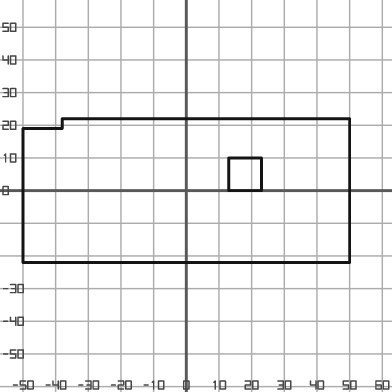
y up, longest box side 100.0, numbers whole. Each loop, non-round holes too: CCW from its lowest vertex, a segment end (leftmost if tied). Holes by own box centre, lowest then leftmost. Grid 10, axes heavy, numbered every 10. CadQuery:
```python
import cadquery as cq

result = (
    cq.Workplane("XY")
    .moveTo(-50.0, -22.0)
    .lineTo(50.0, -22.0)
    .lineTo(50.0, 22.0)
    .lineTo(-38.0, 22.0)
    .lineTo(-38.0, 19.0)
    .lineTo(-50.0, 19.0)
    .close()
    .moveTo(13.0, 0.0)
    .lineTo(23.0, 0.0)
    .lineTo(23.0, 10.0)
    .lineTo(13.0, 10.0)
    .close()
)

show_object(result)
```